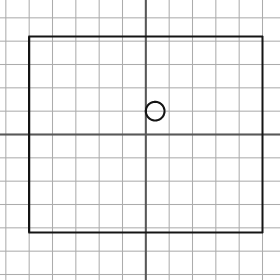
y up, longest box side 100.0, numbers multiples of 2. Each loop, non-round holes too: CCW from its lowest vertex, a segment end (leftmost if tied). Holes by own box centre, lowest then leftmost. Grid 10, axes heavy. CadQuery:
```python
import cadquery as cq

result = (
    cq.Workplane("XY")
    .moveTo(-50.0, -42.0)
    .lineTo(50.0, -42.0)
    .lineTo(50.0, 42.0)
    .lineTo(-50.0, 42.0)
    .close()
    .moveTo(4.0, 10.0)
    .circle(4.0)
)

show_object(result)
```